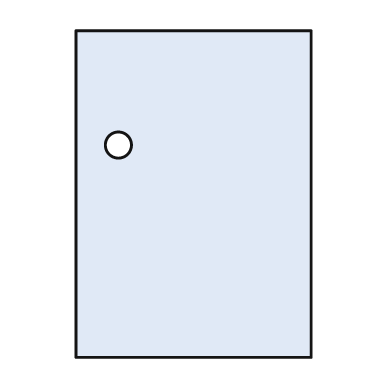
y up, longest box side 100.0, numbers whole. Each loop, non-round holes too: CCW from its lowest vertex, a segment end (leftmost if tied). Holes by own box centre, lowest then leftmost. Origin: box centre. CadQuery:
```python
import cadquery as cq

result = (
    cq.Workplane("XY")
    .moveTo(-36.0, -50.0)
    .lineTo(36.0, -50.0)
    .lineTo(36.0, 50.0)
    .lineTo(-36.0, 50.0)
    .close()
    .moveTo(-23.0, 15.0)
    .circle(4.0)
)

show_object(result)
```